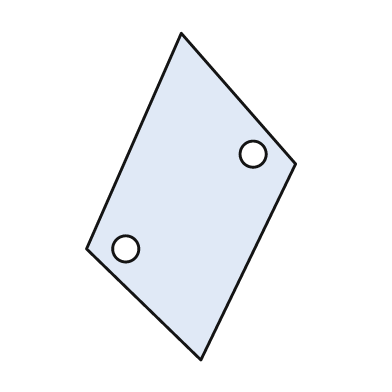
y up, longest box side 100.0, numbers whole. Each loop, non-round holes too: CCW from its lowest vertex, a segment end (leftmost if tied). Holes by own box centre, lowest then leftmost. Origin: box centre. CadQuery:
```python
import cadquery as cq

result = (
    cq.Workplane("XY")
    .moveTo(3.0, -50.0)
    .lineTo(32.0, 10.0)
    .lineTo(-3.0, 50.0)
    .lineTo(-32.0, -16.0)
    .close()
    .moveTo(-20.0, -16.0)
    .circle(4.0)
    .moveTo(19.0, 13.0)
    .circle(4.0)
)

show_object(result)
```